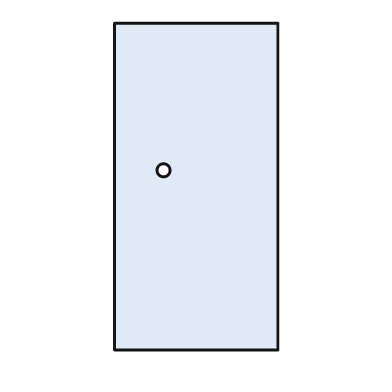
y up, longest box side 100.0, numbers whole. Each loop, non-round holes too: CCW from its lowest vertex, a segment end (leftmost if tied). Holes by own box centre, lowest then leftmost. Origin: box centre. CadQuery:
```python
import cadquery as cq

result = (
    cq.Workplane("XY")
    .moveTo(-25.0, -50.0)
    .lineTo(25.0, -50.0)
    .lineTo(25.0, 50.0)
    .lineTo(-25.0, 50.0)
    .close()
    .moveTo(-10.0, 5.0)
    .circle(2.0)
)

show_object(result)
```